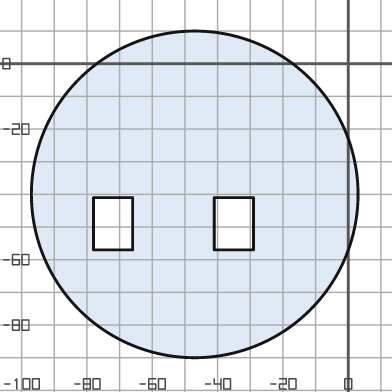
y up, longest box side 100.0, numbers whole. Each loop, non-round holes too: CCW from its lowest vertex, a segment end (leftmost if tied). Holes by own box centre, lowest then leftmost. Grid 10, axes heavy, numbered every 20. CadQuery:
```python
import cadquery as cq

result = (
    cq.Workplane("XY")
    .moveTo(-47.0, -40.0)
    .circle(50.0)
    .moveTo(-78.0, -57.0)
    .lineTo(-66.0, -57.0)
    .lineTo(-66.0, -41.0)
    .lineTo(-78.0, -41.0)
    .close()
    .moveTo(-41.0, -57.0)
    .lineTo(-29.0, -57.0)
    .lineTo(-29.0, -41.0)
    .lineTo(-41.0, -41.0)
    .close()
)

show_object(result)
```